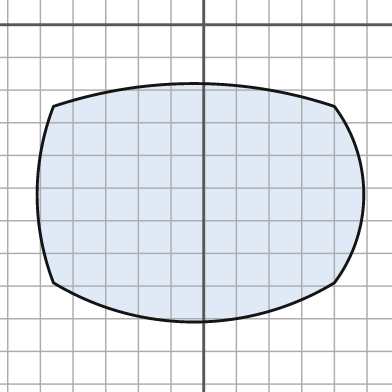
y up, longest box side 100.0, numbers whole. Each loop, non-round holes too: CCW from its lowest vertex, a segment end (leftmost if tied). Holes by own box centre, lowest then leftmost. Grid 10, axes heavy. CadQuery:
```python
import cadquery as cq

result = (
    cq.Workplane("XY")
    .moveTo(-46.0, -79.0)
    .threePointArc((-3.0, -91.0), (40.0, -79.0))
    .threePointArc((49.0, -52.0), (40.0, -25.0))
    .threePointArc((-3.0, -18.0), (-46.0, -25.0))
    .threePointArc((-51.0, -52.0), (-46.0, -79.0))
    .close()
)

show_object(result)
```